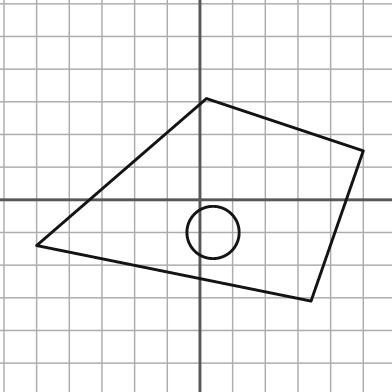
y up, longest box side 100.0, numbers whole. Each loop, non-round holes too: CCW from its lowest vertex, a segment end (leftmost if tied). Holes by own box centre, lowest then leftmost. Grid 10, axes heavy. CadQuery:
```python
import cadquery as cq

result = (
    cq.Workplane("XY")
    .moveTo(34.0, -31.0)
    .lineTo(50.0, 15.0)
    .lineTo(2.0, 31.0)
    .lineTo(-50.0, -14.0)
    .close()
    .moveTo(4.0, -10.0)
    .circle(8.0)
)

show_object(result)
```